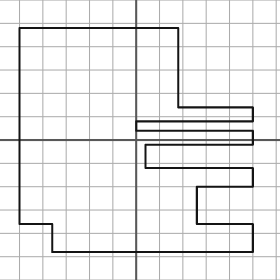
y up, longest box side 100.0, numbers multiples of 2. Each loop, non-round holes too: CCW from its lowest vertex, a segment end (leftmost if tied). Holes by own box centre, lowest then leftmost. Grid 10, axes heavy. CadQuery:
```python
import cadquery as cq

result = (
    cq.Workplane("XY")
    .moveTo(-36.0, -48.0)
    .lineTo(50.0, -48.0)
    .lineTo(50.0, -36.0)
    .lineTo(26.0, -36.0)
    .lineTo(26.0, -20.0)
    .lineTo(50.0, -20.0)
    .lineTo(50.0, -12.0)
    .lineTo(4.0, -12.0)
    .lineTo(4.0, -2.0)
    .lineTo(50.0, -2.0)
    .lineTo(50.0, 4.0)
    .lineTo(0.0, 4.0)
    .lineTo(0.0, 8.0)
    .lineTo(50.0, 8.0)
    .lineTo(50.0, 14.0)
    .lineTo(18.0, 14.0)
    .lineTo(18.0, 48.0)
    .lineTo(-50.0, 48.0)
    .lineTo(-50.0, -36.0)
    .lineTo(-36.0, -36.0)
    .close()
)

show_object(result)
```